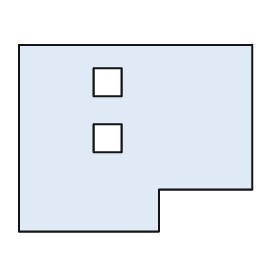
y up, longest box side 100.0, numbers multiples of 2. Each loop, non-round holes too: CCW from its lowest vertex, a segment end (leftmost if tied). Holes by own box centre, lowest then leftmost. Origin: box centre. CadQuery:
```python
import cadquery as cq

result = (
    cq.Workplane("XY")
    .moveTo(-50.0, -40.0)
    .lineTo(10.0, -40.0)
    .lineTo(10.0, -22.0)
    .lineTo(50.0, -22.0)
    .lineTo(50.0, 40.0)
    .lineTo(-50.0, 40.0)
    .close()
    .moveTo(-18.0, -6.0)
    .lineTo(-6.0, -6.0)
    .lineTo(-6.0, 6.0)
    .lineTo(-18.0, 6.0)
    .close()
    .moveTo(-18.0, 18.0)
    .lineTo(-6.0, 18.0)
    .lineTo(-6.0, 30.0)
    .lineTo(-18.0, 30.0)
    .close()
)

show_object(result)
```